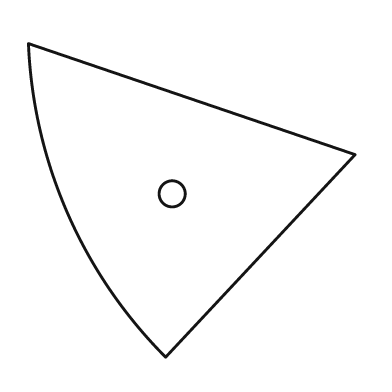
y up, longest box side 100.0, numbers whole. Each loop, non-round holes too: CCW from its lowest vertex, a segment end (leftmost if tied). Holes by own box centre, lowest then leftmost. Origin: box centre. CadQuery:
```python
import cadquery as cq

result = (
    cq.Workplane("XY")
    .moveTo(-8.0, -48.0)
    .lineTo(50.0, 14.0)
    .lineTo(-50.0, 48.0)
    .threePointArc((-38.0, -4.0), (-8.0, -48.0))
    .close()
    .moveTo(-6.0, 2.0)
    .circle(4.0)
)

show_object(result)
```